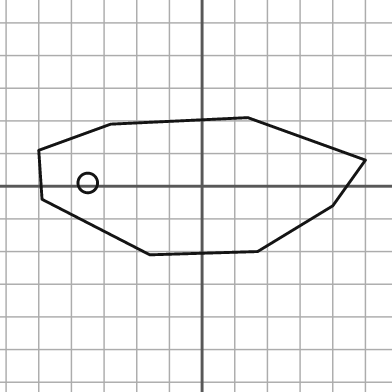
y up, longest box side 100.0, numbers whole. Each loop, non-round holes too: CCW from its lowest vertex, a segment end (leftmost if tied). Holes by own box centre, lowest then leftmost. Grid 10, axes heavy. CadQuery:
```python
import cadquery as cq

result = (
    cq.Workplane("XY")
    .moveTo(-16.0, -21.0)
    .lineTo(17.0, -20.0)
    .lineTo(40.0, -6.0)
    .lineTo(50.0, 8.0)
    .lineTo(14.0, 21.0)
    .lineTo(-28.0, 19.0)
    .lineTo(-50.0, 11.0)
    .lineTo(-49.0, -4.0)
    .close()
    .moveTo(-35.0, 1.0)
    .circle(3.0)
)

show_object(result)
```